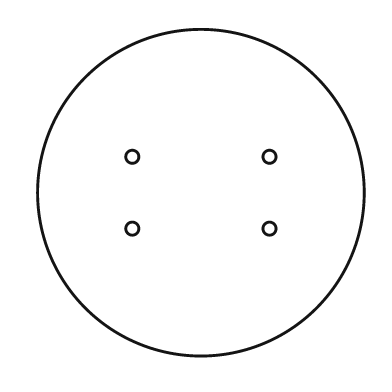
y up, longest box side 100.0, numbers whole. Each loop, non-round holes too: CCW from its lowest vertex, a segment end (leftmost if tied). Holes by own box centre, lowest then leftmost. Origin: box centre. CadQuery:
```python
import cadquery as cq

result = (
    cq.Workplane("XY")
    .moveTo(0.0, 0.0)
    .circle(50.0)
    .moveTo(-21.0, -11.0)
    .circle(2.0)
    .moveTo(21.0, -11.0)
    .circle(2.0)
    .moveTo(-21.0, 11.0)
    .circle(2.0)
    .moveTo(21.0, 11.0)
    .circle(2.0)
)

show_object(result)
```